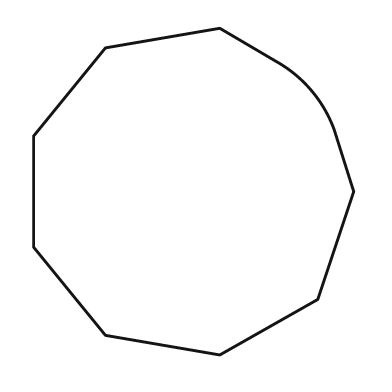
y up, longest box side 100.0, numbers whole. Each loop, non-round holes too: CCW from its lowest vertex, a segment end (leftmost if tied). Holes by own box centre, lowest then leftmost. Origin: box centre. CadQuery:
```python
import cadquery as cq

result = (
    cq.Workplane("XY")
    .moveTo(8.0, -50.0)
    .lineTo(38.0, -33.0)
    .lineTo(49.0, 0.0)
    .lineTo(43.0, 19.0)
    .threePointArc((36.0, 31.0), (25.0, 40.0))
    .lineTo(8.0, 50.0)
    .lineTo(-27.0, 44.0)
    .lineTo(-49.0, 17.0)
    .lineTo(-49.0, -17.0)
    .lineTo(-27.0, -44.0)
    .close()
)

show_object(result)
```